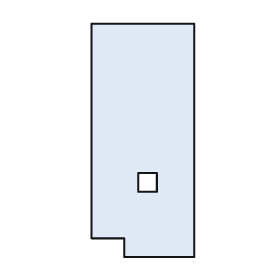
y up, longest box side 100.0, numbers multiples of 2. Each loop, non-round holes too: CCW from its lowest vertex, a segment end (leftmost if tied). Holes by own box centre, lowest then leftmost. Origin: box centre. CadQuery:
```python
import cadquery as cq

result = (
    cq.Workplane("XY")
    .moveTo(-8.0, -50.0)
    .lineTo(22.0, -50.0)
    .lineTo(22.0, 50.0)
    .lineTo(-22.0, 50.0)
    .lineTo(-22.0, -42.0)
    .lineTo(-8.0, -42.0)
    .close()
    .moveTo(-2.0, -22.0)
    .lineTo(6.0, -22.0)
    .lineTo(6.0, -14.0)
    .lineTo(-2.0, -14.0)
    .close()
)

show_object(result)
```